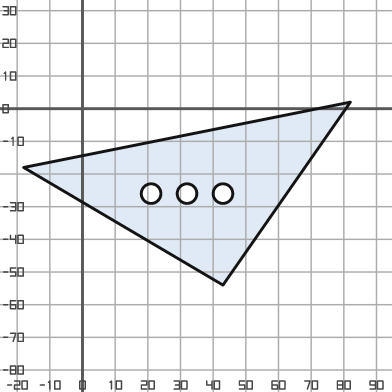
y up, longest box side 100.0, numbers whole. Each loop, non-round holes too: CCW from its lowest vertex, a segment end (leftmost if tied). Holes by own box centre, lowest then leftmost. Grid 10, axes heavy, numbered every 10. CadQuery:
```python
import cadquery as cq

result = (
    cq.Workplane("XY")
    .moveTo(43.0, -54.0)
    .lineTo(82.0, 2.0)
    .lineTo(-18.0, -18.0)
    .close()
    .moveTo(21.0, -26.0)
    .circle(3.0)
    .moveTo(32.0, -26.0)
    .circle(3.0)
    .moveTo(43.0, -26.0)
    .circle(3.0)
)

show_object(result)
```